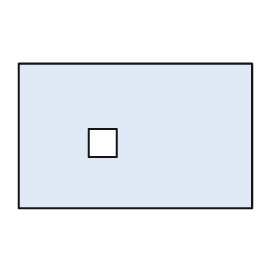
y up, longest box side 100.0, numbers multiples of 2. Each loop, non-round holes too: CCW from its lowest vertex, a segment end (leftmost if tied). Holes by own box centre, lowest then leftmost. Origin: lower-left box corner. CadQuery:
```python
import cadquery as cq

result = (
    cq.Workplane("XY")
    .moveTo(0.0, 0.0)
    .lineTo(100.0, 0.0)
    .lineTo(100.0, 62.0)
    .lineTo(0.0, 62.0)
    .close()
    .moveTo(30.0, 22.0)
    .lineTo(42.0, 22.0)
    .lineTo(42.0, 34.0)
    .lineTo(30.0, 34.0)
    .close()
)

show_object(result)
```